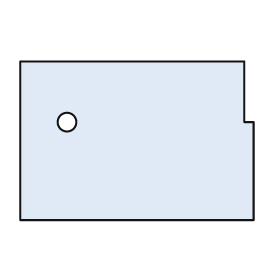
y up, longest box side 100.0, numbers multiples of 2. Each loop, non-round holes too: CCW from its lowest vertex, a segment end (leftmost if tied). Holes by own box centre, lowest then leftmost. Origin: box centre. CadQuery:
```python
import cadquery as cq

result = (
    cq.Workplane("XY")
    .moveTo(-50.0, -34.0)
    .lineTo(50.0, -34.0)
    .lineTo(50.0, 8.0)
    .lineTo(46.0, 8.0)
    .lineTo(46.0, 34.0)
    .lineTo(-50.0, 34.0)
    .close()
    .moveTo(-30.0, 8.0)
    .circle(4.0)
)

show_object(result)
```